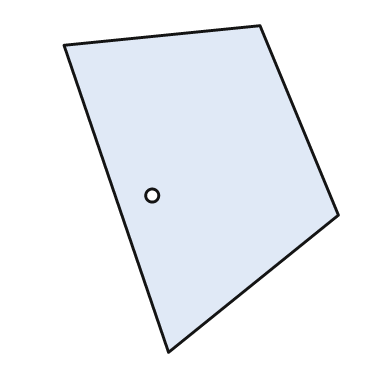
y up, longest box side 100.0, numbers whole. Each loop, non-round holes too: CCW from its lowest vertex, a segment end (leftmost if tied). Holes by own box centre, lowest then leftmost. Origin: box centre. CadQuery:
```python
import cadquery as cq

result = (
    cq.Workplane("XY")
    .moveTo(-10.0, -50.0)
    .lineTo(42.0, -8.0)
    .lineTo(18.0, 50.0)
    .lineTo(-42.0, 44.0)
    .close()
    .moveTo(-15.0, -2.0)
    .circle(2.0)
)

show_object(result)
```